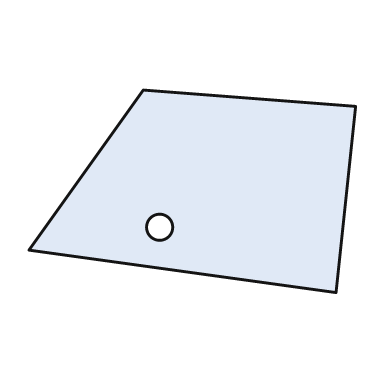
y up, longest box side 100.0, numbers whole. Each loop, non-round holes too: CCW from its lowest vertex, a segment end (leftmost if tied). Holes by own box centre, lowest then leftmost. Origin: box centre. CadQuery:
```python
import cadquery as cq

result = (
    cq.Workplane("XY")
    .moveTo(44.0, -31.0)
    .lineTo(50.0, 26.0)
    .lineTo(-15.0, 31.0)
    .lineTo(-50.0, -18.0)
    .close()
    .moveTo(-10.0, -11.0)
    .circle(4.0)
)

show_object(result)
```